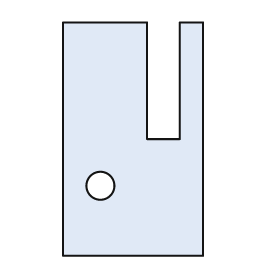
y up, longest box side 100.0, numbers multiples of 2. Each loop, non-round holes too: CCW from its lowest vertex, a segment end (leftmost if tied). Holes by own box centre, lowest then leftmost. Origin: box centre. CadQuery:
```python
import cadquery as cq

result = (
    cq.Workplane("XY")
    .moveTo(-30.0, -50.0)
    .lineTo(30.0, -50.0)
    .lineTo(30.0, 50.0)
    .lineTo(20.0, 50.0)
    .lineTo(20.0, 0.0)
    .lineTo(6.0, 0.0)
    .lineTo(6.0, 50.0)
    .lineTo(-30.0, 50.0)
    .close()
    .moveTo(-14.0, -20.0)
    .circle(6.0)
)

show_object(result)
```